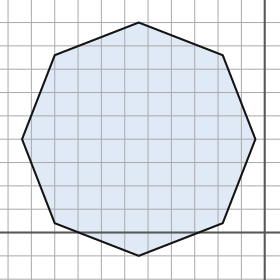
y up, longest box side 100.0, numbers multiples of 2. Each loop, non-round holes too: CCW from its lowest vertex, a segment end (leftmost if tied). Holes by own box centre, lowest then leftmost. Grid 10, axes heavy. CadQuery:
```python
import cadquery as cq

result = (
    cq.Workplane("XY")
    .moveTo(-54.0, -10.0)
    .lineTo(-18.0, 4.0)
    .lineTo(-4.0, 40.0)
    .lineTo(-18.0, 76.0)
    .lineTo(-54.0, 90.0)
    .lineTo(-90.0, 76.0)
    .lineTo(-104.0, 40.0)
    .lineTo(-90.0, 4.0)
    .close()
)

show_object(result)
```